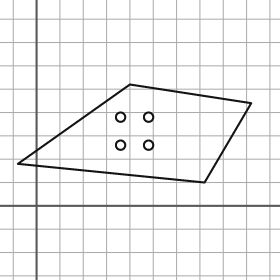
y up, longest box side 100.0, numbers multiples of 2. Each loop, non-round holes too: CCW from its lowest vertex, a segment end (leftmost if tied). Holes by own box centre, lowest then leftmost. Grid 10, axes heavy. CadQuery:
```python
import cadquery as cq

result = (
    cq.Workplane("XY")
    .moveTo(72.0, 10.0)
    .lineTo(92.0, 44.0)
    .lineTo(40.0, 52.0)
    .lineTo(-8.0, 18.0)
    .close()
    .moveTo(36.0, 26.0)
    .circle(2.0)
    .moveTo(48.0, 26.0)
    .circle(2.0)
    .moveTo(36.0, 38.0)
    .circle(2.0)
    .moveTo(48.0, 38.0)
    .circle(2.0)
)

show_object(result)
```